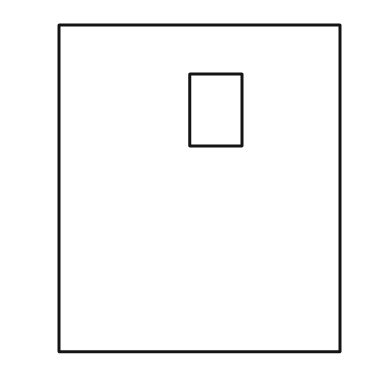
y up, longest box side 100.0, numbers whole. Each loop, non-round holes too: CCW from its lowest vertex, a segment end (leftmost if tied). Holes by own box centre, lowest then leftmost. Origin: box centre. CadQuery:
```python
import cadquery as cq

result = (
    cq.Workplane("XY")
    .moveTo(-43.0, -50.0)
    .lineTo(43.0, -50.0)
    .lineTo(43.0, 50.0)
    .lineTo(-43.0, 50.0)
    .close()
    .moveTo(-3.0, 13.0)
    .lineTo(13.0, 13.0)
    .lineTo(13.0, 35.0)
    .lineTo(-3.0, 35.0)
    .close()
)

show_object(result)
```